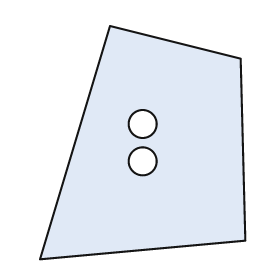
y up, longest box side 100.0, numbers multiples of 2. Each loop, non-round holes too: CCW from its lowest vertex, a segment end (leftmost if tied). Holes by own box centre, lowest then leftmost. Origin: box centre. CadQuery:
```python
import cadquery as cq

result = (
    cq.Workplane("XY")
    .moveTo(-44.0, -50.0)
    .lineTo(44.0, -42.0)
    .lineTo(42.0, 36.0)
    .lineTo(-14.0, 50.0)
    .close()
    .moveTo(0.0, -8.0)
    .circle(6.0)
    .moveTo(0.0, 8.0)
    .circle(6.0)
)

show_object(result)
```